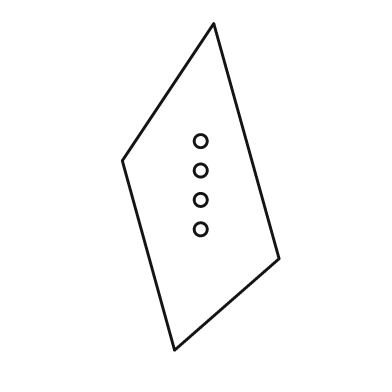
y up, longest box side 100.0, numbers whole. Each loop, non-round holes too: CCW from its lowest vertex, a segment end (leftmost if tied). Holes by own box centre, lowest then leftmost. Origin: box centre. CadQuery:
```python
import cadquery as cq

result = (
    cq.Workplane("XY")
    .moveTo(-8.0, -50.0)
    .lineTo(24.0, -22.0)
    .lineTo(4.0, 50.0)
    .lineTo(-24.0, 8.0)
    .close()
    .moveTo(0.0, -13.0)
    .circle(2.0)
    .moveTo(0.0, -4.0)
    .circle(2.0)
    .moveTo(0.0, 5.0)
    .circle(2.0)
    .moveTo(0.0, 14.0)
    .circle(2.0)
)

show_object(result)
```